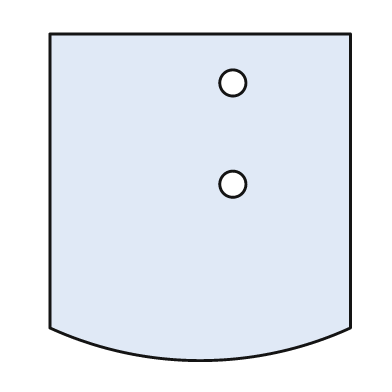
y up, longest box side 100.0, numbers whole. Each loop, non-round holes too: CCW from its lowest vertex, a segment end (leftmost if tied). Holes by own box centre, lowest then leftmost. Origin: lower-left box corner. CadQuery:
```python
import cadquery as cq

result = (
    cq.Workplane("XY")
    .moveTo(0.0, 10.0)
    .threePointArc((46.0, 0.0), (92.0, 10.0))
    .lineTo(92.0, 100.0)
    .lineTo(0.0, 100.0)
    .close()
    .moveTo(56.0, 54.0)
    .circle(4.0)
    .moveTo(56.0, 85.0)
    .circle(4.0)
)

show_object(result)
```